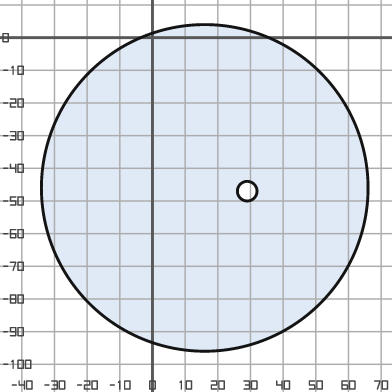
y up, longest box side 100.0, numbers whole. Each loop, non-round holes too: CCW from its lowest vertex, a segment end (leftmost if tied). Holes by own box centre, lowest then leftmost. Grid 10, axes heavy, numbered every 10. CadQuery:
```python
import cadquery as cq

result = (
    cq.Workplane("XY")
    .moveTo(16.0, -46.0)
    .circle(50.0)
    .moveTo(29.0, -47.0)
    .circle(3.0)
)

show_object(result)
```